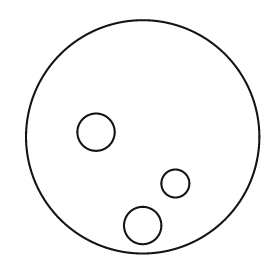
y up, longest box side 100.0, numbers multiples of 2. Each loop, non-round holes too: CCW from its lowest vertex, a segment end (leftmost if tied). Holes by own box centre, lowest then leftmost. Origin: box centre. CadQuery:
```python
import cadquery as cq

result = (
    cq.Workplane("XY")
    .moveTo(0.0, 0.0)
    .circle(50.0)
    .moveTo(0.0, -38.0)
    .circle(8.0)
    .moveTo(14.0, -20.0)
    .circle(6.0)
    .moveTo(-20.0, 2.0)
    .circle(8.0)
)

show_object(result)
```